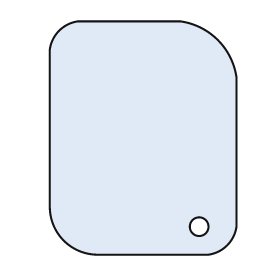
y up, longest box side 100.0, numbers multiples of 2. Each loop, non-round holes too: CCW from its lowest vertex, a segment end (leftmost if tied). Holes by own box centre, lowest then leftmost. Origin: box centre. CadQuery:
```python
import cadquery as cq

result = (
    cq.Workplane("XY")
    .moveTo(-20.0, -50.0)
    .lineTo(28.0, -50.0)
    .threePointArc((36.0, -46.0), (40.0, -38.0))
    .lineTo(40.0, 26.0)
    .threePointArc((32.0, 42.0), (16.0, 50.0))
    .lineTo(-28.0, 50.0)
    .threePointArc((-36.0, 46.0), (-40.0, 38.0))
    .lineTo(-40.0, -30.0)
    .threePointArc((-34.0, -44.0), (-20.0, -50.0))
    .close()
    .moveTo(24.0, -38.0)
    .circle(4.0)
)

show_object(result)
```